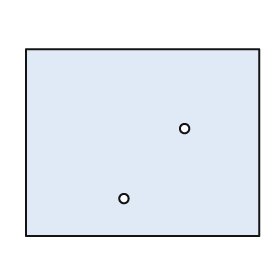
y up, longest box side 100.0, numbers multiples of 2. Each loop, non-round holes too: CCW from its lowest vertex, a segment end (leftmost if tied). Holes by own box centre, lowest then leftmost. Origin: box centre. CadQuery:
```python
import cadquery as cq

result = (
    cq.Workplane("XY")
    .moveTo(-50.0, -40.0)
    .lineTo(50.0, -40.0)
    .lineTo(50.0, 40.0)
    .lineTo(-50.0, 40.0)
    .close()
    .moveTo(-8.0, -24.0)
    .circle(2.0)
    .moveTo(18.0, 6.0)
    .circle(2.0)
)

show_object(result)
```